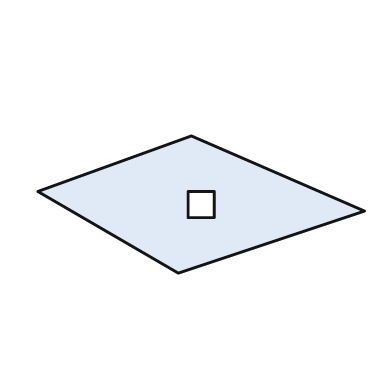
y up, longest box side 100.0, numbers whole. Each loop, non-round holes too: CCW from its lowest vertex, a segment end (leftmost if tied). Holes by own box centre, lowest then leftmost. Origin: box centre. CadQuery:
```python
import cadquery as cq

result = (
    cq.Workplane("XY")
    .moveTo(-7.0, -21.0)
    .lineTo(50.0, -2.0)
    .lineTo(-3.0, 21.0)
    .lineTo(-50.0, 4.0)
    .close()
    .moveTo(-4.0, -4.0)
    .lineTo(4.0, -4.0)
    .lineTo(4.0, 4.0)
    .lineTo(-4.0, 4.0)
    .close()
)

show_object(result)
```